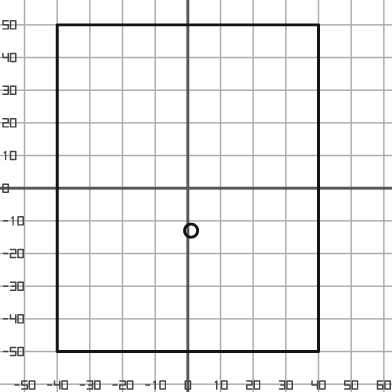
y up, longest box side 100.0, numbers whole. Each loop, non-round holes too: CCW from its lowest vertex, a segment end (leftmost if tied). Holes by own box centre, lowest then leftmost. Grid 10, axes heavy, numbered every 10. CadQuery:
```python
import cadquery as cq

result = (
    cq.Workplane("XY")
    .moveTo(-40.0, -50.0)
    .lineTo(40.0, -50.0)
    .lineTo(40.0, 50.0)
    .lineTo(-40.0, 50.0)
    .close()
    .moveTo(1.0, -13.0)
    .circle(2.0)
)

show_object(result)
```